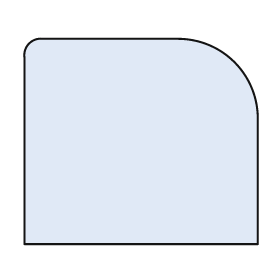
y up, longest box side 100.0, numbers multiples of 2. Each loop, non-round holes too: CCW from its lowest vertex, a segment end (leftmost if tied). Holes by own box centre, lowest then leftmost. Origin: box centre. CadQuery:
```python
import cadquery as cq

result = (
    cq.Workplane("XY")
    .moveTo(-50.0, -44.0)
    .lineTo(50.0, -44.0)
    .lineTo(50.0, 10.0)
    .threePointArc((40.0, 34.0), (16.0, 44.0))
    .lineTo(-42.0, 44.0)
    .threePointArc((-48.0, 42.0), (-50.0, 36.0))
    .close()
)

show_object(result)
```